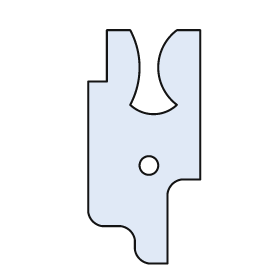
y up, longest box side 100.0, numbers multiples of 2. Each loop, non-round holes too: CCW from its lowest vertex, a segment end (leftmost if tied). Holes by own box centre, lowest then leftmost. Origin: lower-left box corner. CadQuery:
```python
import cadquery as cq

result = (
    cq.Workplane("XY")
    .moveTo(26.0, 0.0)
    .lineTo(34.0, 0.0)
    .lineTo(34.0, 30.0)
    .threePointArc((36.0, 34.0), (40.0, 36.0))
    .lineTo(48.0, 36.0)
    .lineTo(48.0, 100.0)
    .lineTo(38.0, 100.0)
    .threePointArc((30.0, 84.0), (38.0, 68.0))
    .threePointArc((28.0, 64.0), (18.0, 68.0))
    .threePointArc((22.0, 84.0), (18.0, 100.0))
    .lineTo(8.0, 100.0)
    .lineTo(8.0, 78.0)
    .lineTo(0.0, 78.0)
    .lineTo(0.0, 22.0)
    .threePointArc((2.0, 18.0), (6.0, 16.0))
    .lineTo(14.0, 16.0)
    .threePointArc((18.0, 14.0), (20.0, 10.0))
    .lineTo(20.0, 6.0)
    .threePointArc((22.0, 2.0), (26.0, 0.0))
    .close()
    .moveTo(26.0, 42.0)
    .circle(4.0)
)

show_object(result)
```